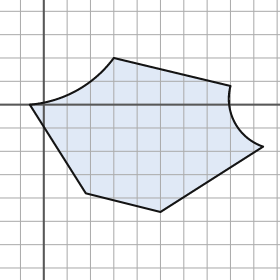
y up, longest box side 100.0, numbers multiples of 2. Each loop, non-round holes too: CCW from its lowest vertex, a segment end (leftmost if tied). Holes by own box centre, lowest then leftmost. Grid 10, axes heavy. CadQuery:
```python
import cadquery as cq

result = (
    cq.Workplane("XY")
    .moveTo(50.0, -46.0)
    .lineTo(94.0, -18.0)
    .threePointArc((82.0, -8.0), (80.0, 8.0))
    .lineTo(30.0, 20.0)
    .threePointArc((14.0, 6.0), (-6.0, 0.0))
    .lineTo(18.0, -38.0)
    .close()
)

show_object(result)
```